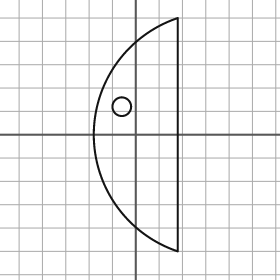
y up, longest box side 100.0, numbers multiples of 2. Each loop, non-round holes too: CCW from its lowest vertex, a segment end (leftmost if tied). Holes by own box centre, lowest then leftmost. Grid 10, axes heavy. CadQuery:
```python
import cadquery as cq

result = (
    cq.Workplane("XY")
    .moveTo(18.0, -50.0)
    .lineTo(18.0, 50.0)
    .threePointArc((-18.0, 0.0), (18.0, -50.0))
    .close()
    .moveTo(-6.0, 12.0)
    .circle(4.0)
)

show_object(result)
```